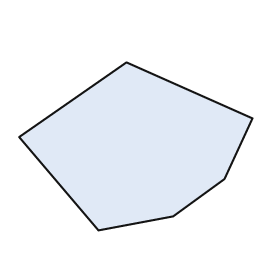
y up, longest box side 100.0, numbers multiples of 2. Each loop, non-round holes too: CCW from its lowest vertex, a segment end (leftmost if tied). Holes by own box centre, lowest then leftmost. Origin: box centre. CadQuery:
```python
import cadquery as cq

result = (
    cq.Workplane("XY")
    .moveTo(-16.0, -36.0)
    .lineTo(16.0, -30.0)
    .lineTo(38.0, -14.0)
    .lineTo(50.0, 12.0)
    .lineTo(-4.0, 36.0)
    .lineTo(-50.0, 4.0)
    .close()
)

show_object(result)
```